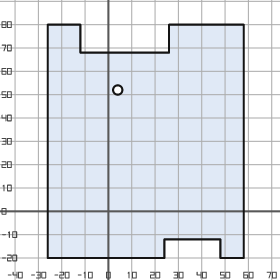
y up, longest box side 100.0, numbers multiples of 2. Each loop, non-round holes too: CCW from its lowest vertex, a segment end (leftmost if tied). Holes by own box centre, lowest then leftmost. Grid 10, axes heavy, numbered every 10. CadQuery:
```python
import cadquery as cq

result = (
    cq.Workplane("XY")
    .moveTo(-26.0, -20.0)
    .lineTo(24.0, -20.0)
    .lineTo(24.0, -12.0)
    .lineTo(48.0, -12.0)
    .lineTo(48.0, -20.0)
    .lineTo(58.0, -20.0)
    .lineTo(58.0, 80.0)
    .lineTo(26.0, 80.0)
    .lineTo(26.0, 68.0)
    .lineTo(-12.0, 68.0)
    .lineTo(-12.0, 80.0)
    .lineTo(-26.0, 80.0)
    .close()
    .moveTo(4.0, 52.0)
    .circle(2.0)
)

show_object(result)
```